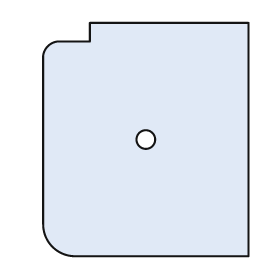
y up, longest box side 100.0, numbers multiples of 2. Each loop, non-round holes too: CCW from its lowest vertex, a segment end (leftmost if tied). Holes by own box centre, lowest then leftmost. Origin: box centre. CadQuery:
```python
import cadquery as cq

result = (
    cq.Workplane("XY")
    .moveTo(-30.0, -50.0)
    .lineTo(44.0, -50.0)
    .lineTo(44.0, 50.0)
    .lineTo(-24.0, 50.0)
    .lineTo(-24.0, 42.0)
    .lineTo(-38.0, 42.0)
    .threePointArc((-42.0, 40.0), (-44.0, 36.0))
    .lineTo(-44.0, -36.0)
    .threePointArc((-40.0, -46.0), (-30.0, -50.0))
    .close()
    .moveTo(0.0, 0.0)
    .circle(4.0)
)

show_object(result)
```